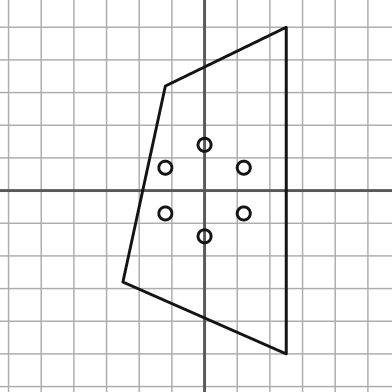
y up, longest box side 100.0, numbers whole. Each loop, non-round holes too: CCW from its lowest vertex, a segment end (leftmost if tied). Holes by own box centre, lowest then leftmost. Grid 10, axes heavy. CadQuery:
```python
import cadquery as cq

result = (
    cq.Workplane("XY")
    .moveTo(25.0, -50.0)
    .lineTo(25.0, 50.0)
    .lineTo(-12.0, 32.0)
    .lineTo(-25.0, -28.0)
    .close()
    .moveTo(0.0, -14.0)
    .circle(2.0)
    .moveTo(-12.0, -7.0)
    .circle(2.0)
    .moveTo(12.0, -7.0)
    .circle(2.0)
    .moveTo(-12.0, 7.0)
    .circle(2.0)
    .moveTo(12.0, 7.0)
    .circle(2.0)
    .moveTo(0.0, 14.0)
    .circle(2.0)
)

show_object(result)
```